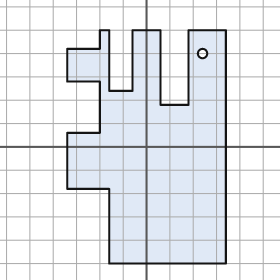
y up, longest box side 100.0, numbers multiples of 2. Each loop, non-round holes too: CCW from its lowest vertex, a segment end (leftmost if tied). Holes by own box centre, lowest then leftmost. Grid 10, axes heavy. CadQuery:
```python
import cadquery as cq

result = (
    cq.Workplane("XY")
    .moveTo(-16.0, -50.0)
    .lineTo(34.0, -50.0)
    .lineTo(34.0, 50.0)
    .lineTo(18.0, 50.0)
    .lineTo(18.0, 18.0)
    .lineTo(6.0, 18.0)
    .lineTo(6.0, 50.0)
    .lineTo(-6.0, 50.0)
    .lineTo(-6.0, 24.0)
    .lineTo(-16.0, 24.0)
    .lineTo(-16.0, 50.0)
    .lineTo(-20.0, 50.0)
    .lineTo(-20.0, 42.0)
    .lineTo(-34.0, 42.0)
    .lineTo(-34.0, 28.0)
    .lineTo(-20.0, 28.0)
    .lineTo(-20.0, 6.0)
    .lineTo(-34.0, 6.0)
    .lineTo(-34.0, -18.0)
    .lineTo(-16.0, -18.0)
    .close()
    .moveTo(24.0, 40.0)
    .circle(2.0)
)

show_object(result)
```